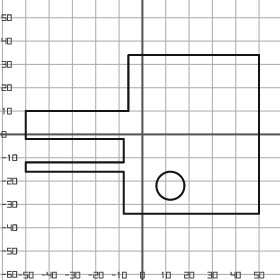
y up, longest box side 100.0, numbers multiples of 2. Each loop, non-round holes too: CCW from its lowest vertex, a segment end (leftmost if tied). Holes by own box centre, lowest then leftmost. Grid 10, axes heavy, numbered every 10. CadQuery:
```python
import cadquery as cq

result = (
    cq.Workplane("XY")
    .moveTo(-8.0, -34.0)
    .lineTo(50.0, -34.0)
    .lineTo(50.0, 34.0)
    .lineTo(-6.0, 34.0)
    .lineTo(-6.0, 10.0)
    .lineTo(-50.0, 10.0)
    .lineTo(-50.0, -2.0)
    .lineTo(-8.0, -2.0)
    .lineTo(-8.0, -12.0)
    .lineTo(-50.0, -12.0)
    .lineTo(-50.0, -16.0)
    .lineTo(-8.0, -16.0)
    .close()
    .moveTo(12.0, -22.0)
    .circle(6.0)
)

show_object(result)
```